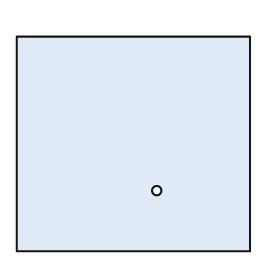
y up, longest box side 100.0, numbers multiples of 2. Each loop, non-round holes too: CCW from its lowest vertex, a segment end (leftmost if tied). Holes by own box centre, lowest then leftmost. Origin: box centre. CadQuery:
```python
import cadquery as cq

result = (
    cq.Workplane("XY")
    .moveTo(-50.0, -46.0)
    .lineTo(50.0, -46.0)
    .lineTo(50.0, 46.0)
    .lineTo(-50.0, 46.0)
    .close()
    .moveTo(10.0, -20.0)
    .circle(2.0)
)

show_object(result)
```